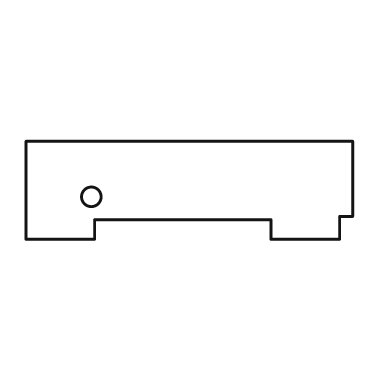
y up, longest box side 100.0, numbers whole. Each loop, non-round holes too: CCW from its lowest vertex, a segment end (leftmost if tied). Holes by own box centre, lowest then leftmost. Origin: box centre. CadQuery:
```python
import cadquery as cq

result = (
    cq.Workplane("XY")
    .moveTo(-50.0, -15.0)
    .lineTo(-29.0, -15.0)
    .lineTo(-29.0, -9.0)
    .lineTo(25.0, -9.0)
    .lineTo(25.0, -15.0)
    .lineTo(46.0, -15.0)
    .lineTo(46.0, -8.0)
    .lineTo(50.0, -8.0)
    .lineTo(50.0, 15.0)
    .lineTo(-50.0, 15.0)
    .close()
    .moveTo(-30.0, -2.0)
    .circle(3.0)
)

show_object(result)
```